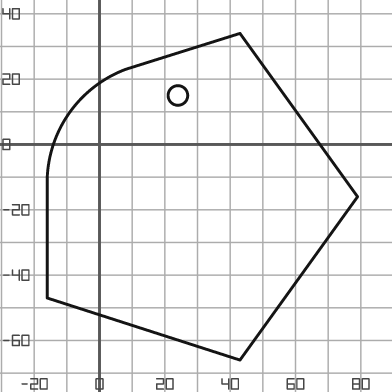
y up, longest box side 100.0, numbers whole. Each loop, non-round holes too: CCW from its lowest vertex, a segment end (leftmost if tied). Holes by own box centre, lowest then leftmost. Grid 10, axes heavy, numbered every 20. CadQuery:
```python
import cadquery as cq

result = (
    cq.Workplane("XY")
    .moveTo(43.0, -66.0)
    .lineTo(79.0, -16.0)
    .lineTo(43.0, 34.0)
    .lineTo(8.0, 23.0)
    .threePointArc((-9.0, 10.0), (-16.0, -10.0))
    .lineTo(-16.0, -47.0)
    .close()
    .moveTo(24.0, 15.0)
    .circle(3.0)
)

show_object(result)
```